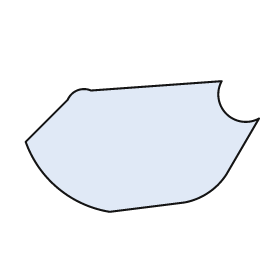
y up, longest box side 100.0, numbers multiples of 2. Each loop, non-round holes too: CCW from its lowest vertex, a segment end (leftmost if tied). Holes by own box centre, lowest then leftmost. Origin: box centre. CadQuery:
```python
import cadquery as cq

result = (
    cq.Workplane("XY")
    .moveTo(-14.0, -28.0)
    .lineTo(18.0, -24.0)
    .threePointArc((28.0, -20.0), (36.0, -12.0))
    .lineTo(50.0, 12.0)
    .threePointArc((36.0, 14.0), (34.0, 28.0))
    .lineTo(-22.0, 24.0)
    .threePointArc((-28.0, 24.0), (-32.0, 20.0))
    .lineTo(-50.0, 2.0)
    .threePointArc((-36.0, -18.0), (-14.0, -28.0))
    .close()
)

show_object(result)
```